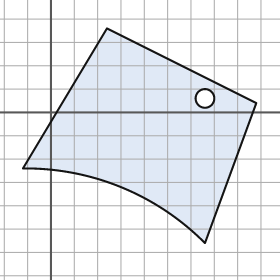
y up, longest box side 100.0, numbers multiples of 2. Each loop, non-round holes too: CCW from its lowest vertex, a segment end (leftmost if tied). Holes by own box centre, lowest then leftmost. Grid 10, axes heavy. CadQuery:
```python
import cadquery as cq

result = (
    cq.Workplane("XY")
    .moveTo(66.0, -56.0)
    .lineTo(88.0, 4.0)
    .lineTo(24.0, 36.0)
    .lineTo(-12.0, -24.0)
    .threePointArc((30.0, -32.0), (66.0, -56.0))
    .close()
    .moveTo(66.0, 6.0)
    .circle(4.0)
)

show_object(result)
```